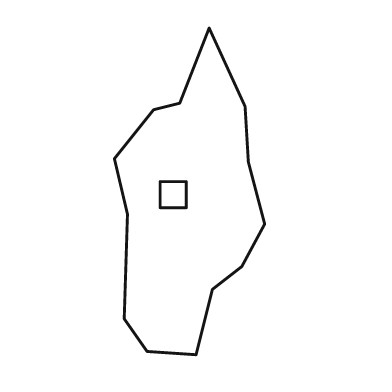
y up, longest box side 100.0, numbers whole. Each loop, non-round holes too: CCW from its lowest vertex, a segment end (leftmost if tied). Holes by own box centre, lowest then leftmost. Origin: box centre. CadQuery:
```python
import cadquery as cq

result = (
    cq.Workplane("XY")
    .moveTo(2.0, -50.0)
    .lineTo(7.0, -30.0)
    .lineTo(16.0, -23.0)
    .lineTo(23.0, -10.0)
    .lineTo(18.0, 9.0)
    .lineTo(17.0, 26.0)
    .lineTo(6.0, 50.0)
    .lineTo(-3.0, 27.0)
    .lineTo(-11.0, 25.0)
    .lineTo(-23.0, 10.0)
    .lineTo(-19.0, -7.0)
    .lineTo(-20.0, -39.0)
    .lineTo(-13.0, -49.0)
    .close()
    .moveTo(-9.0, -5.0)
    .lineTo(-1.0, -5.0)
    .lineTo(-1.0, 3.0)
    .lineTo(-9.0, 3.0)
    .close()
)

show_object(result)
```